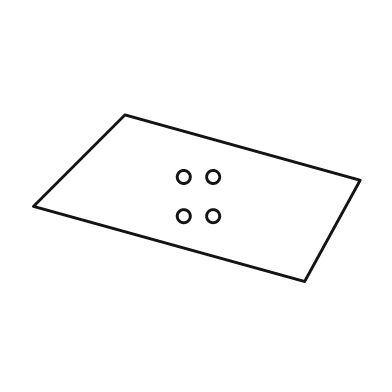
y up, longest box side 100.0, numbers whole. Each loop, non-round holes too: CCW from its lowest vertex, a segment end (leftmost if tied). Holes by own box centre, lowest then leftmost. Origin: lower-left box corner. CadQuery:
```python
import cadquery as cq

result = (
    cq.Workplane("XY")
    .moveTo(83.0, 0.0)
    .lineTo(100.0, 31.0)
    .lineTo(28.0, 51.0)
    .lineTo(0.0, 23.0)
    .close()
    .moveTo(46.0, 20.0)
    .circle(2.0)
    .moveTo(55.0, 20.0)
    .circle(2.0)
    .moveTo(46.0, 32.0)
    .circle(2.0)
    .moveTo(55.0, 32.0)
    .circle(2.0)
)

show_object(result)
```